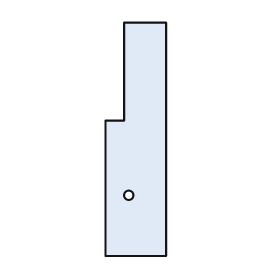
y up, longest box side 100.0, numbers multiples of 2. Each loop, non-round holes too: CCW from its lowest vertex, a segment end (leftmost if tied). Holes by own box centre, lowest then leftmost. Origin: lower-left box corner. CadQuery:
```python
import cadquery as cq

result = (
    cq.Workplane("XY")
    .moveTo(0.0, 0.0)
    .lineTo(26.0, 0.0)
    .lineTo(26.0, 100.0)
    .lineTo(8.0, 100.0)
    .lineTo(8.0, 58.0)
    .lineTo(0.0, 58.0)
    .close()
    .moveTo(10.0, 26.0)
    .circle(2.0)
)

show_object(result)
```